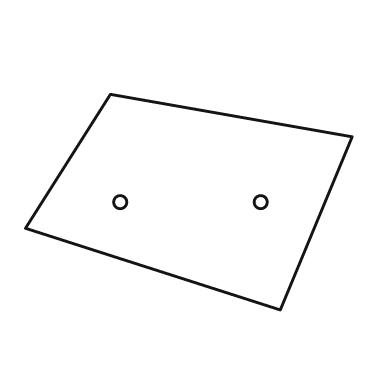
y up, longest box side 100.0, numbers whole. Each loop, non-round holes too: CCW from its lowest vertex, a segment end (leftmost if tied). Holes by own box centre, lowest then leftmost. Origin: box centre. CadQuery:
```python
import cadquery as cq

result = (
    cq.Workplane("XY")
    .moveTo(28.0, -33.0)
    .lineTo(50.0, 20.0)
    .lineTo(-24.0, 33.0)
    .lineTo(-50.0, -8.0)
    .close()
    .moveTo(-21.0, 0.0)
    .circle(2.0)
    .moveTo(22.0, 0.0)
    .circle(2.0)
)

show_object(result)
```